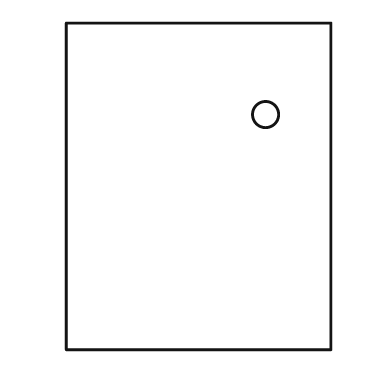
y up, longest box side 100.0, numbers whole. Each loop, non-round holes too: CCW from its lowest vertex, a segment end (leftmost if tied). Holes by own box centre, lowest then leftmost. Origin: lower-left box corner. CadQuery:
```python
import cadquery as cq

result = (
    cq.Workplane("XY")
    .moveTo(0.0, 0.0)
    .lineTo(81.0, 0.0)
    .lineTo(81.0, 100.0)
    .lineTo(0.0, 100.0)
    .close()
    .moveTo(61.0, 72.0)
    .circle(4.0)
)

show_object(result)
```